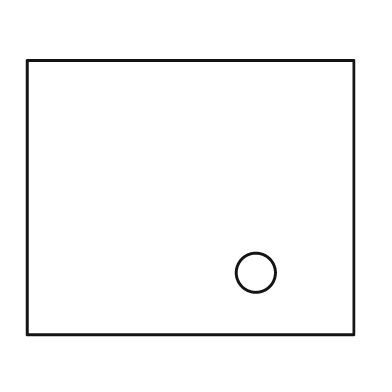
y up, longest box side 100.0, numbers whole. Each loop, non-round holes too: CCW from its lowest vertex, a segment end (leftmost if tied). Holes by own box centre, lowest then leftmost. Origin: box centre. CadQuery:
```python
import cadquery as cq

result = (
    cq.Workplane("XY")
    .moveTo(-50.0, -42.0)
    .lineTo(50.0, -42.0)
    .lineTo(50.0, 42.0)
    .lineTo(-50.0, 42.0)
    .close()
    .moveTo(20.0, -23.0)
    .circle(6.0)
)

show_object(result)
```